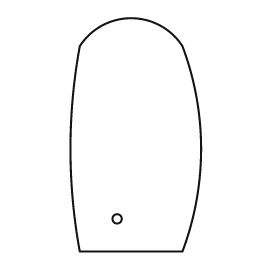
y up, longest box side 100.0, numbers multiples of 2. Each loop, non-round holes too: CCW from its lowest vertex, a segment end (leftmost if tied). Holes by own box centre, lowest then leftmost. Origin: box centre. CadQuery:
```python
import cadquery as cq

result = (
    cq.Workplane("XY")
    .moveTo(-24.0, -50.0)
    .lineTo(20.0, -50.0)
    .threePointArc((28.0, -6.0), (20.0, 38.0))
    .threePointArc((-2.0, 50.0), (-24.0, 38.0))
    .threePointArc((-28.0, -6.0), (-24.0, -50.0))
    .close()
    .moveTo(-8.0, -36.0)
    .circle(2.0)
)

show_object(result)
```